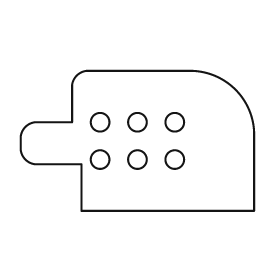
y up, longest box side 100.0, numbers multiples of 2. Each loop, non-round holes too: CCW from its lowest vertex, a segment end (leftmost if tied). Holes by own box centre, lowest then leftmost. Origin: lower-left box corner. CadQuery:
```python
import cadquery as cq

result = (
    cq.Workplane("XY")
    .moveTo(26.0, 0.0)
    .lineTo(100.0, 0.0)
    .lineTo(100.0, 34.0)
    .threePointArc((92.0, 52.0), (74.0, 60.0))
    .lineTo(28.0, 60.0)
    .threePointArc((24.0, 58.0), (22.0, 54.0))
    .lineTo(22.0, 38.0)
    .lineTo(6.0, 38.0)
    .threePointArc((2.0, 36.0), (0.0, 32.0))
    .lineTo(0.0, 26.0)
    .threePointArc((2.0, 22.0), (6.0, 20.0))
    .lineTo(26.0, 20.0)
    .close()
    .moveTo(34.0, 22.0)
    .circle(4.0)
    .moveTo(50.0, 22.0)
    .circle(4.0)
    .moveTo(66.0, 22.0)
    .circle(4.0)
    .moveTo(34.0, 38.0)
    .circle(4.0)
    .moveTo(50.0, 38.0)
    .circle(4.0)
    .moveTo(66.0, 38.0)
    .circle(4.0)
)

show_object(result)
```